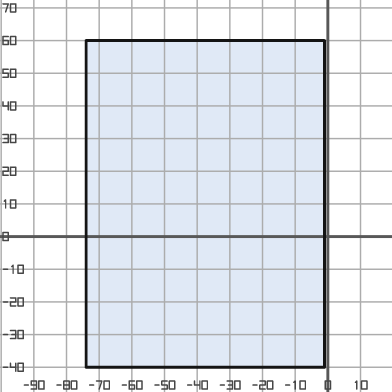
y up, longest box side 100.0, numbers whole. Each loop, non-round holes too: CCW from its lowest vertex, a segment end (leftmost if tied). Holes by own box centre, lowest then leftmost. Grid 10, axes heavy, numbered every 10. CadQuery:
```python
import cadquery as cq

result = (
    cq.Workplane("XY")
    .moveTo(-74.0, -40.0)
    .lineTo(-1.0, -40.0)
    .lineTo(-1.0, 60.0)
    .lineTo(-74.0, 60.0)
    .close()
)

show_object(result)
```